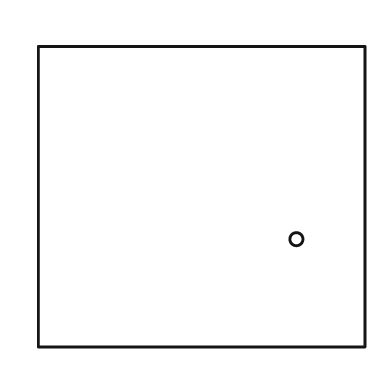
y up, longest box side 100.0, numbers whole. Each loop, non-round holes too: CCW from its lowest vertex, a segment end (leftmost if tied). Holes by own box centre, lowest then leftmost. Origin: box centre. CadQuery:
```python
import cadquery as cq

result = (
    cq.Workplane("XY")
    .moveTo(-50.0, -46.0)
    .lineTo(50.0, -46.0)
    .lineTo(50.0, 46.0)
    .lineTo(-50.0, 46.0)
    .close()
    .moveTo(29.0, -13.0)
    .circle(2.0)
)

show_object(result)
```